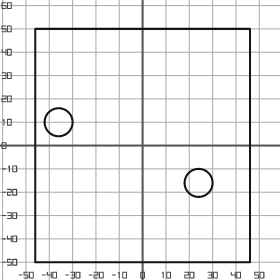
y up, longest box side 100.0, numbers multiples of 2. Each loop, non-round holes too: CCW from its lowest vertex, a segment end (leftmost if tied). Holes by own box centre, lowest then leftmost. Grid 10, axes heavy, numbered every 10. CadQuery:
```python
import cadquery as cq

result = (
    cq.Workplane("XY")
    .moveTo(-46.0, -50.0)
    .lineTo(46.0, -50.0)
    .lineTo(46.0, 50.0)
    .lineTo(-46.0, 50.0)
    .close()
    .moveTo(24.0, -16.0)
    .circle(6.0)
    .moveTo(-36.0, 10.0)
    .circle(6.0)
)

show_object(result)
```